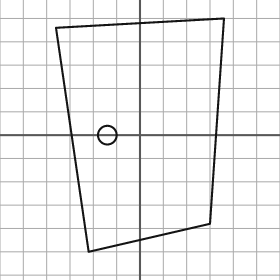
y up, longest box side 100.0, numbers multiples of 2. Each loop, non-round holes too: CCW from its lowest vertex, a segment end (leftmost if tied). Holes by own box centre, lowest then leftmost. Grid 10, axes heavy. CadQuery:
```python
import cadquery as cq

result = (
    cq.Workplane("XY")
    .moveTo(-22.0, -50.0)
    .lineTo(30.0, -38.0)
    .lineTo(36.0, 50.0)
    .lineTo(-36.0, 46.0)
    .close()
    .moveTo(-14.0, 0.0)
    .circle(4.0)
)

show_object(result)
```